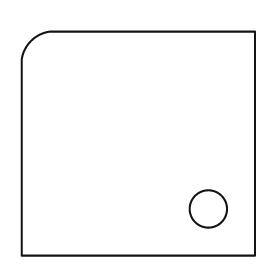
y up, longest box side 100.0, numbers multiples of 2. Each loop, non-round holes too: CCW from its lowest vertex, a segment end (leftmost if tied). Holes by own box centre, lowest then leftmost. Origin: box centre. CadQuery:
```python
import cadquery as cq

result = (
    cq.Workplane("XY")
    .moveTo(-50.0, -48.0)
    .lineTo(50.0, -48.0)
    .lineTo(50.0, 48.0)
    .lineTo(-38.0, 48.0)
    .threePointArc((-46.0, 44.0), (-50.0, 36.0))
    .close()
    .moveTo(30.0, -28.0)
    .circle(8.0)
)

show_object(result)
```